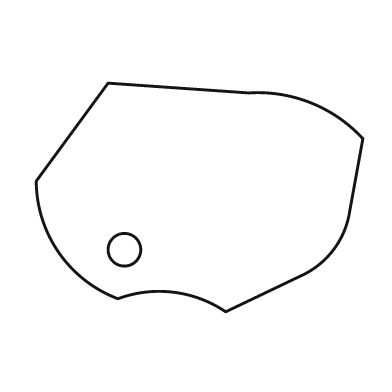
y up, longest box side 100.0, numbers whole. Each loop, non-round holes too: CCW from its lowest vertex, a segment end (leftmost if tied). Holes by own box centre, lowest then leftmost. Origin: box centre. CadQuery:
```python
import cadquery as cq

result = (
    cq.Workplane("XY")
    .moveTo(8.0, -35.0)
    .lineTo(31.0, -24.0)
    .threePointArc((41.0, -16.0), (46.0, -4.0))
    .lineTo(50.0, 18.0)
    .threePointArc((34.0, 29.0), (15.0, 32.0))
    .lineTo(-28.0, 35.0)
    .lineTo(-50.0, 5.0)
    .threePointArc((-43.0, -17.0), (-25.0, -31.0))
    .threePointArc((-8.0, -29.0), (8.0, -35.0))
    .close()
    .moveTo(-23.0, -16.0)
    .circle(5.0)
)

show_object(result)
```